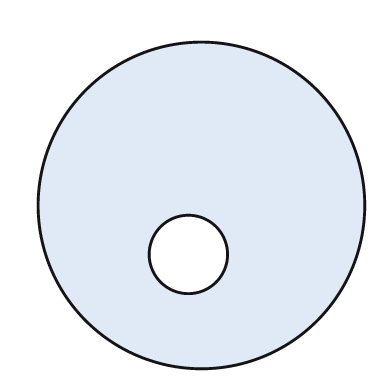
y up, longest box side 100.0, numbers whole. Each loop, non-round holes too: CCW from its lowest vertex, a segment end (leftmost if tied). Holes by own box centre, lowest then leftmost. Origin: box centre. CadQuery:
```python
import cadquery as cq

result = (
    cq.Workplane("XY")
    .moveTo(0.0, 0.0)
    .circle(50.0)
    .moveTo(-4.0, -15.0)
    .circle(12.0)
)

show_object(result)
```